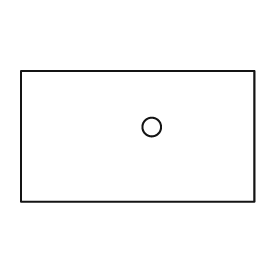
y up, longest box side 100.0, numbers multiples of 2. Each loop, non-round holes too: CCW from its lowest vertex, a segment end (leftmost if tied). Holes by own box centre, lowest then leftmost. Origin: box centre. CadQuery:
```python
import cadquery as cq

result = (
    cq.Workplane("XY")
    .moveTo(-50.0, -28.0)
    .lineTo(50.0, -28.0)
    .lineTo(50.0, 28.0)
    .lineTo(-50.0, 28.0)
    .close()
    .moveTo(6.0, 4.0)
    .circle(4.0)
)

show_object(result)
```